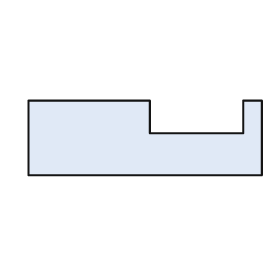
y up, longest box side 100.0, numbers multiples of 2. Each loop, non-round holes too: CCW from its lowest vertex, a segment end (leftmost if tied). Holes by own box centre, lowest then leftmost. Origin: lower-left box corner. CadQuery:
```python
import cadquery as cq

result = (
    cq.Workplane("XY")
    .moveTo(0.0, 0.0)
    .lineTo(100.0, 0.0)
    .lineTo(100.0, 32.0)
    .lineTo(92.0, 32.0)
    .lineTo(92.0, 18.0)
    .lineTo(52.0, 18.0)
    .lineTo(52.0, 32.0)
    .lineTo(0.0, 32.0)
    .close()
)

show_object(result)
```